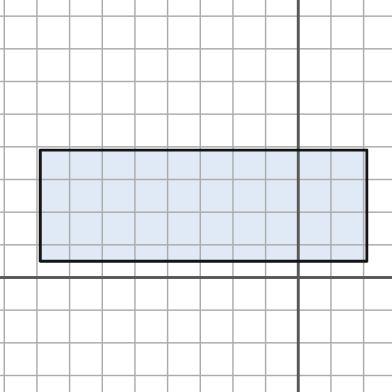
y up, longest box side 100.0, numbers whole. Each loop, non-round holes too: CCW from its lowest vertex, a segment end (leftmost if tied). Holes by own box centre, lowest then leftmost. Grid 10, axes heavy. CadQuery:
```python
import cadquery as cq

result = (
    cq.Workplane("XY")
    .moveTo(-79.0, 5.0)
    .lineTo(21.0, 5.0)
    .lineTo(21.0, 39.0)
    .lineTo(-79.0, 39.0)
    .close()
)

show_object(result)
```